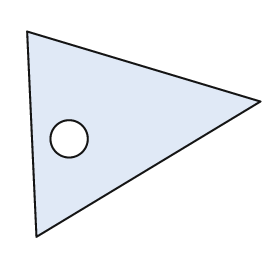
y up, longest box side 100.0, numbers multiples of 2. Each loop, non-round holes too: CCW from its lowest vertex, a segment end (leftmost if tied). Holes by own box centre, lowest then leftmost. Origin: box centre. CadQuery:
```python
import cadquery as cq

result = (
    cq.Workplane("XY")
    .moveTo(-46.0, -44.0)
    .lineTo(50.0, 14.0)
    .lineTo(-50.0, 44.0)
    .close()
    .moveTo(-32.0, -2.0)
    .circle(8.0)
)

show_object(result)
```